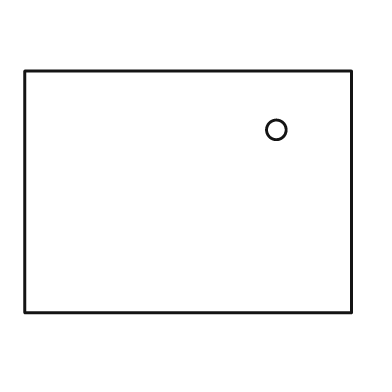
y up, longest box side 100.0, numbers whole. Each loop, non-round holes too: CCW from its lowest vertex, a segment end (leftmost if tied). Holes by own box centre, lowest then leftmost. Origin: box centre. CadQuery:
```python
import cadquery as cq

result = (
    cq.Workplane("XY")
    .moveTo(-50.0, -37.0)
    .lineTo(50.0, -37.0)
    .lineTo(50.0, 37.0)
    .lineTo(-50.0, 37.0)
    .close()
    .moveTo(27.0, 19.0)
    .circle(3.0)
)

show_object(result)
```